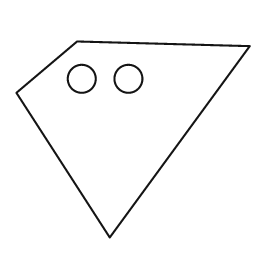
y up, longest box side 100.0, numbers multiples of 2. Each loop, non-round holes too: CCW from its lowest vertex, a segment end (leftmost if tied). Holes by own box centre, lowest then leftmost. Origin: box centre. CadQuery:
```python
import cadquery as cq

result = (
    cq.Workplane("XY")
    .moveTo(-10.0, -42.0)
    .lineTo(50.0, 40.0)
    .lineTo(-24.0, 42.0)
    .lineTo(-50.0, 20.0)
    .close()
    .moveTo(-22.0, 26.0)
    .circle(6.0)
    .moveTo(-2.0, 26.0)
    .circle(6.0)
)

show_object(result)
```